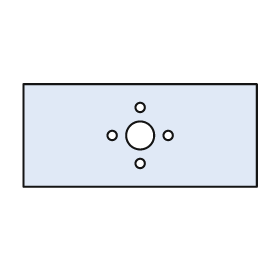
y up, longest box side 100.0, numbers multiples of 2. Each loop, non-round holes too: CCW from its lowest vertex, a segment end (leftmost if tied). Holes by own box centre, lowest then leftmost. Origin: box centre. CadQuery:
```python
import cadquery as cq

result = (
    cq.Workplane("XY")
    .moveTo(-50.0, -22.0)
    .lineTo(50.0, -22.0)
    .lineTo(50.0, 22.0)
    .lineTo(-50.0, 22.0)
    .close()
    .moveTo(0.0, -12.0)
    .circle(2.0)
    .moveTo(-12.0, 0.0)
    .circle(2.0)
    .moveTo(0.0, 0.0)
    .circle(6.0)
    .moveTo(12.0, 0.0)
    .circle(2.0)
    .moveTo(0.0, 12.0)
    .circle(2.0)
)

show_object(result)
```